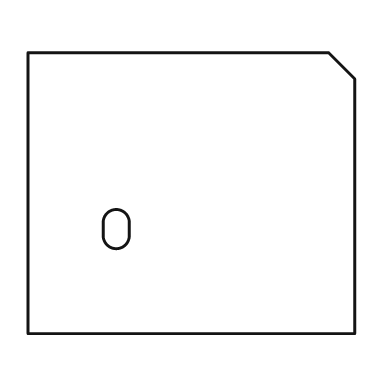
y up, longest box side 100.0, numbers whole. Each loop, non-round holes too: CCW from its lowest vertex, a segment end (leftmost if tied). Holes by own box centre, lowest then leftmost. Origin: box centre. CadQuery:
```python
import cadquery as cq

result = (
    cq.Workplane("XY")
    .moveTo(-50.0, -43.0)
    .lineTo(50.0, -43.0)
    .lineTo(50.0, 35.0)
    .lineTo(42.0, 43.0)
    .lineTo(-50.0, 43.0)
    .close()
    .moveTo(-27.0, -13.0)
    .threePointArc((-23.0, -17.0), (-19.0, -13.0))
    .lineTo(-19.0, -9.0)
    .threePointArc((-23.0, -5.0), (-27.0, -9.0))
    .close()
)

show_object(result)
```